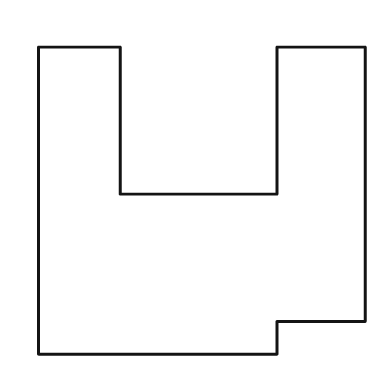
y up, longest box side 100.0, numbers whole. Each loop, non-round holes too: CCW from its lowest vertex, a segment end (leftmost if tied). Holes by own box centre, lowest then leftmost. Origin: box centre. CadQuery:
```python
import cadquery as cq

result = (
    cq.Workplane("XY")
    .moveTo(-50.0, -47.0)
    .lineTo(23.0, -47.0)
    .lineTo(23.0, -37.0)
    .lineTo(50.0, -37.0)
    .lineTo(50.0, 47.0)
    .lineTo(23.0, 47.0)
    .lineTo(23.0, 2.0)
    .lineTo(-25.0, 2.0)
    .lineTo(-25.0, 47.0)
    .lineTo(-50.0, 47.0)
    .close()
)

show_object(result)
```